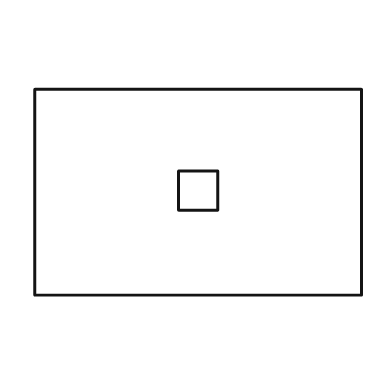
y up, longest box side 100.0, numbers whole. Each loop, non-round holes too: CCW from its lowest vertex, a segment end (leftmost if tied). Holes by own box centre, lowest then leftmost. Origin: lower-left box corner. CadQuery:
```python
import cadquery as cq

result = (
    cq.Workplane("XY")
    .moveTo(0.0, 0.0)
    .lineTo(100.0, 0.0)
    .lineTo(100.0, 63.0)
    .lineTo(0.0, 63.0)
    .close()
    .moveTo(44.0, 26.0)
    .lineTo(56.0, 26.0)
    .lineTo(56.0, 38.0)
    .lineTo(44.0, 38.0)
    .close()
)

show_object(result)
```